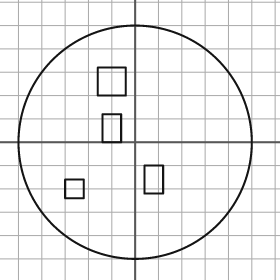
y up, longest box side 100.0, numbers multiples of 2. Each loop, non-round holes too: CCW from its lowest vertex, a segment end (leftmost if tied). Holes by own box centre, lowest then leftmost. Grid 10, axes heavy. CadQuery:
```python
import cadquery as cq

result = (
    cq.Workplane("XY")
    .moveTo(0.0, 0.0)
    .circle(50.0)
    .moveTo(-30.0, -24.0)
    .lineTo(-22.0, -24.0)
    .lineTo(-22.0, -16.0)
    .lineTo(-30.0, -16.0)
    .close()
    .moveTo(4.0, -22.0)
    .lineTo(12.0, -22.0)
    .lineTo(12.0, -10.0)
    .lineTo(4.0, -10.0)
    .close()
    .moveTo(-14.0, 0.0)
    .lineTo(-6.0, 0.0)
    .lineTo(-6.0, 12.0)
    .lineTo(-14.0, 12.0)
    .close()
    .moveTo(-16.0, 20.0)
    .lineTo(-4.0, 20.0)
    .lineTo(-4.0, 32.0)
    .lineTo(-16.0, 32.0)
    .close()
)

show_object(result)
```